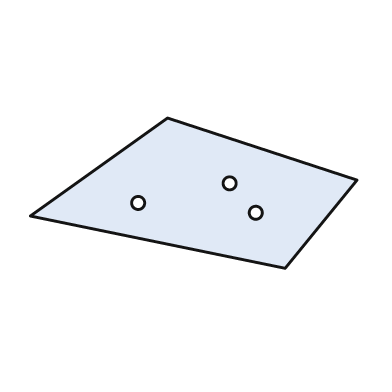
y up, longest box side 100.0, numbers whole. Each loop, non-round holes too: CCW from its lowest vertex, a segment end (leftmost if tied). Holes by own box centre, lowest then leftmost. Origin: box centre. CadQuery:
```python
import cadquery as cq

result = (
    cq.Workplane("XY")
    .moveTo(28.0, -23.0)
    .lineTo(50.0, 4.0)
    .lineTo(-8.0, 23.0)
    .lineTo(-50.0, -7.0)
    .close()
    .moveTo(19.0, -6.0)
    .circle(2.0)
    .moveTo(-17.0, -3.0)
    .circle(2.0)
    .moveTo(11.0, 3.0)
    .circle(2.0)
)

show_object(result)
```